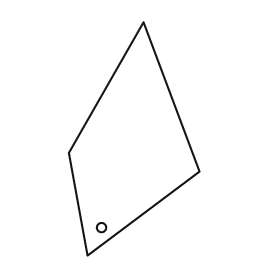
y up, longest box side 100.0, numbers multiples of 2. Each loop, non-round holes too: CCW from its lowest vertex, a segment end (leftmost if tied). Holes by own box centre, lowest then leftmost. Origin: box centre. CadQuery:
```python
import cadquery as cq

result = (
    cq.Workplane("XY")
    .moveTo(-20.0, -50.0)
    .lineTo(28.0, -14.0)
    .lineTo(4.0, 50.0)
    .lineTo(-28.0, -6.0)
    .close()
    .moveTo(-14.0, -38.0)
    .circle(2.0)
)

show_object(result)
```